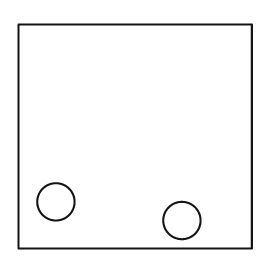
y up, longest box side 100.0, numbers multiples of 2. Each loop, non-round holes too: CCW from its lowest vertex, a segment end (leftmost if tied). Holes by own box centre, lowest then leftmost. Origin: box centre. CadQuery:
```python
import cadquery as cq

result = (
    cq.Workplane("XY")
    .moveTo(-50.0, -48.0)
    .lineTo(50.0, -48.0)
    .lineTo(50.0, 48.0)
    .lineTo(-50.0, 48.0)
    .close()
    .moveTo(20.0, -36.0)
    .circle(8.0)
    .moveTo(-34.0, -28.0)
    .circle(8.0)
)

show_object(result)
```